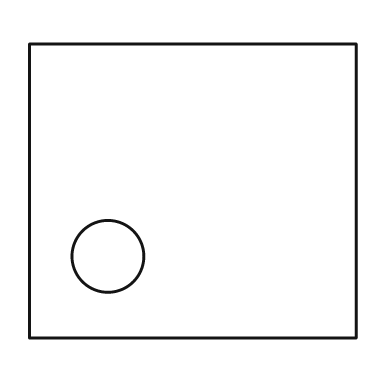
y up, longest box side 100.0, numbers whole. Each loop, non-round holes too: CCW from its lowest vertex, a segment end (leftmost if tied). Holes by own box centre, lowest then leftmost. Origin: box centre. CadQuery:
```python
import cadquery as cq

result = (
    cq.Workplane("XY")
    .moveTo(-50.0, -45.0)
    .lineTo(50.0, -45.0)
    .lineTo(50.0, 45.0)
    .lineTo(-50.0, 45.0)
    .close()
    .moveTo(-26.0, -20.0)
    .circle(11.0)
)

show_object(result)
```